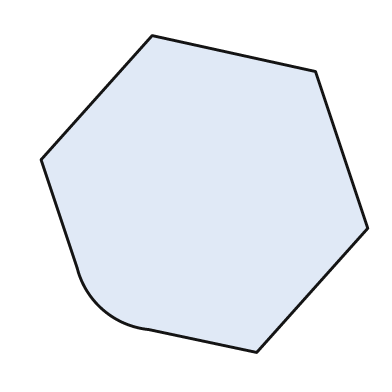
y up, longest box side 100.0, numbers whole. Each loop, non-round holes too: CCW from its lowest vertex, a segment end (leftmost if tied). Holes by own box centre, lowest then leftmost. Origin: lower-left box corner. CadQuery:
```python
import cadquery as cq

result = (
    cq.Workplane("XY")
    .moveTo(66.0, 0.0)
    .lineTo(100.0, 38.0)
    .lineTo(84.0, 86.0)
    .lineTo(34.0, 97.0)
    .lineTo(0.0, 59.0)
    .lineTo(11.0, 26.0)
    .threePointArc((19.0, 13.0), (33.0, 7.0))
    .close()
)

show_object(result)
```